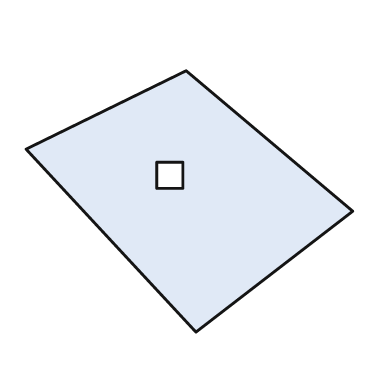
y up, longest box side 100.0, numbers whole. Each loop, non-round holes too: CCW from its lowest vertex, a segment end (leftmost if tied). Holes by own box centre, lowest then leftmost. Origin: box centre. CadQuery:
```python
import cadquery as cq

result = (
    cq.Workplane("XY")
    .moveTo(2.0, -40.0)
    .lineTo(50.0, -3.0)
    .lineTo(-1.0, 40.0)
    .lineTo(-50.0, 16.0)
    .close()
    .moveTo(-10.0, 4.0)
    .lineTo(-2.0, 4.0)
    .lineTo(-2.0, 12.0)
    .lineTo(-10.0, 12.0)
    .close()
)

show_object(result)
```